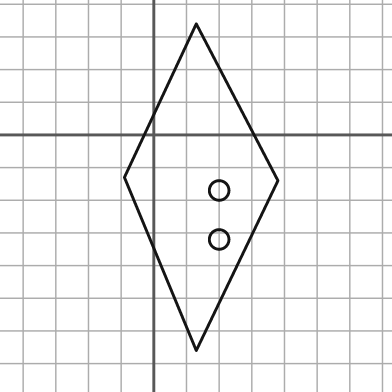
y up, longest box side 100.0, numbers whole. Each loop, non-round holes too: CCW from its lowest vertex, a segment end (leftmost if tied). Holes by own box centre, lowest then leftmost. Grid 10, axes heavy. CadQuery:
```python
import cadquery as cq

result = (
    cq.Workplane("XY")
    .moveTo(13.0, -66.0)
    .lineTo(38.0, -14.0)
    .lineTo(13.0, 34.0)
    .lineTo(-9.0, -13.0)
    .close()
    .moveTo(20.0, -32.0)
    .circle(3.0)
    .moveTo(20.0, -17.0)
    .circle(3.0)
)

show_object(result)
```